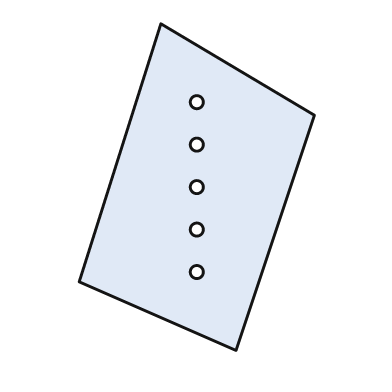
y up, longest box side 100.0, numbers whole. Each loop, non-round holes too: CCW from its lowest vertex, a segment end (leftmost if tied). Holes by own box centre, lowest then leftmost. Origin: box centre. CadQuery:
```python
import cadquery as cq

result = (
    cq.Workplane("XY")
    .moveTo(12.0, -50.0)
    .lineTo(36.0, 22.0)
    .lineTo(-11.0, 50.0)
    .lineTo(-36.0, -29.0)
    .close()
    .moveTo(0.0, -26.0)
    .circle(2.0)
    .moveTo(0.0, -13.0)
    .circle(2.0)
    .moveTo(0.0, 0.0)
    .circle(2.0)
    .moveTo(0.0, 13.0)
    .circle(2.0)
    .moveTo(0.0, 26.0)
    .circle(2.0)
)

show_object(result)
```